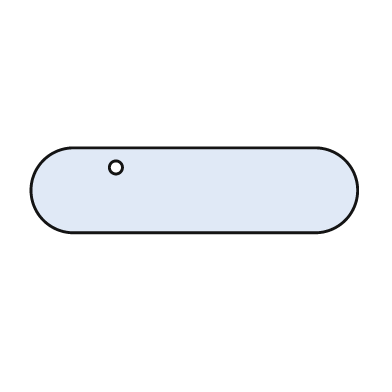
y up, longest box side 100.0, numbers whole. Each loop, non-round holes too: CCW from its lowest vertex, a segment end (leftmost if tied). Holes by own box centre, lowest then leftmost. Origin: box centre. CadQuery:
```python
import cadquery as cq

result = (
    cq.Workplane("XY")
    .moveTo(-37.0, -13.0)
    .lineTo(37.0, -13.0)
    .threePointArc((50.0, 0.0), (37.0, 13.0))
    .lineTo(-37.0, 13.0)
    .threePointArc((-50.0, 0.0), (-37.0, -13.0))
    .close()
    .moveTo(-24.0, 7.0)
    .circle(2.0)
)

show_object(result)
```